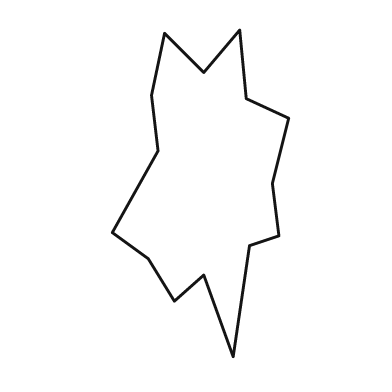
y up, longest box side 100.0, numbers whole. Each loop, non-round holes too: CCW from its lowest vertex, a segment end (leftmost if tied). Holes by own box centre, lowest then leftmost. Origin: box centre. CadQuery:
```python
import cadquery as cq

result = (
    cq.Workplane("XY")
    .moveTo(10.0, -50.0)
    .lineTo(15.0, -16.0)
    .lineTo(24.0, -13.0)
    .lineTo(22.0, 3.0)
    .lineTo(27.0, 23.0)
    .lineTo(14.0, 29.0)
    .lineTo(12.0, 50.0)
    .lineTo(1.0, 37.0)
    .lineTo(-11.0, 49.0)
    .lineTo(-15.0, 30.0)
    .lineTo(-13.0, 13.0)
    .lineTo(-27.0, -12.0)
    .lineTo(-16.0, -20.0)
    .lineTo(-8.0, -33.0)
    .lineTo(1.0, -25.0)
    .close()
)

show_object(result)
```